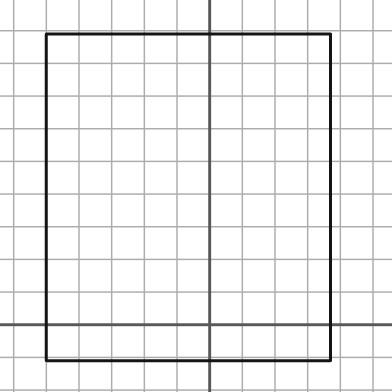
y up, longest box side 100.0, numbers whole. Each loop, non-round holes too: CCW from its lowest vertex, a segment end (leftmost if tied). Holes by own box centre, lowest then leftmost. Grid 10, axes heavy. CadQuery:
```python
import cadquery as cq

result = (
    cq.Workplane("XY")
    .moveTo(-50.0, -11.0)
    .lineTo(37.0, -11.0)
    .lineTo(37.0, 89.0)
    .lineTo(-50.0, 89.0)
    .close()
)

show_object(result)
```